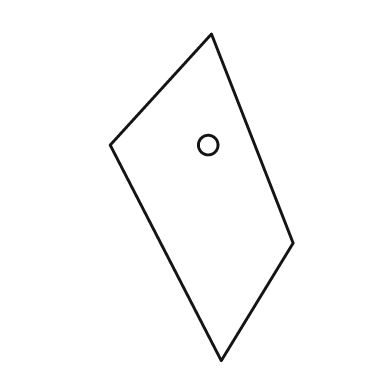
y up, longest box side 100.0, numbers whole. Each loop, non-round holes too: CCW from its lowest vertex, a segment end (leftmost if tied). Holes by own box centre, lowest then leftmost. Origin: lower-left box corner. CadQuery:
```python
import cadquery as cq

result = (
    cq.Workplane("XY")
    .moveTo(34.0, 0.0)
    .lineTo(56.0, 36.0)
    .lineTo(31.0, 100.0)
    .lineTo(0.0, 66.0)
    .close()
    .moveTo(30.0, 66.0)
    .circle(3.0)
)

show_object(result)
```